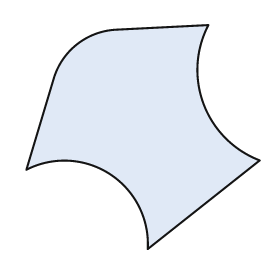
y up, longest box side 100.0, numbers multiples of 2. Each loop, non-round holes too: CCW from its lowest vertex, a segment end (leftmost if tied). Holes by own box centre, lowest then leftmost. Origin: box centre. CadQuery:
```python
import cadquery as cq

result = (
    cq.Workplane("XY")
    .moveTo(2.0, -48.0)
    .lineTo(50.0, -10.0)
    .threePointArc((26.0, 14.0), (28.0, 48.0))
    .lineTo(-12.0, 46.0)
    .threePointArc((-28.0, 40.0), (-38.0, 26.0))
    .lineTo(-50.0, -14.0)
    .threePointArc((-14.0, -16.0), (2.0, -48.0))
    .close()
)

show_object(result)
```